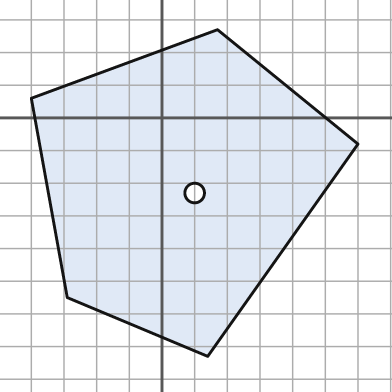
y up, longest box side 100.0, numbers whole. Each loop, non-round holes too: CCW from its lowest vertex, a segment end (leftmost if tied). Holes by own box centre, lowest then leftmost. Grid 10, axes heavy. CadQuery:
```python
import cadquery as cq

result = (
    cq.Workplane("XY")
    .moveTo(14.0, -73.0)
    .lineTo(60.0, -8.0)
    .lineTo(17.0, 27.0)
    .lineTo(-40.0, 6.0)
    .lineTo(-29.0, -55.0)
    .close()
    .moveTo(10.0, -23.0)
    .circle(3.0)
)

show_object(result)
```